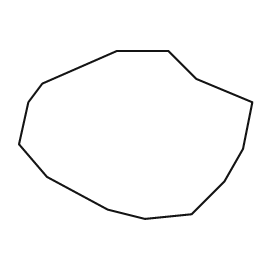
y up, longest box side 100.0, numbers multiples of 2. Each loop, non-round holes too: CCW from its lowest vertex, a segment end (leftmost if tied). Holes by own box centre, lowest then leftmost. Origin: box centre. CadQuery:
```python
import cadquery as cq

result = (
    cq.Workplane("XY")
    .moveTo(4.0, -36.0)
    .lineTo(24.0, -34.0)
    .lineTo(38.0, -20.0)
    .lineTo(46.0, -6.0)
    .lineTo(50.0, 14.0)
    .lineTo(26.0, 24.0)
    .lineTo(14.0, 36.0)
    .lineTo(-8.0, 36.0)
    .lineTo(-40.0, 22.0)
    .lineTo(-46.0, 14.0)
    .lineTo(-50.0, -4.0)
    .lineTo(-38.0, -18.0)
    .lineTo(-12.0, -32.0)
    .close()
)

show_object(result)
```